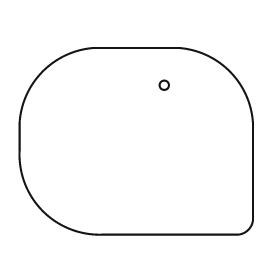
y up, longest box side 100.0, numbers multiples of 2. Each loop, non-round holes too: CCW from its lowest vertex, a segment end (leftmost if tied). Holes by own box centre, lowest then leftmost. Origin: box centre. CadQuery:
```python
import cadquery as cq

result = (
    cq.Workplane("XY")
    .moveTo(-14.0, -40.0)
    .lineTo(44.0, -40.0)
    .threePointArc((48.0, -38.0), (50.0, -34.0))
    .lineTo(50.0, 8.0)
    .threePointArc((40.0, 30.0), (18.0, 40.0))
    .lineTo(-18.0, 40.0)
    .threePointArc((-40.0, 30.0), (-50.0, 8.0))
    .lineTo(-50.0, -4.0)
    .threePointArc((-40.0, -30.0), (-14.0, -40.0))
    .close()
    .moveTo(12.0, 24.0)
    .circle(2.0)
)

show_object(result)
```